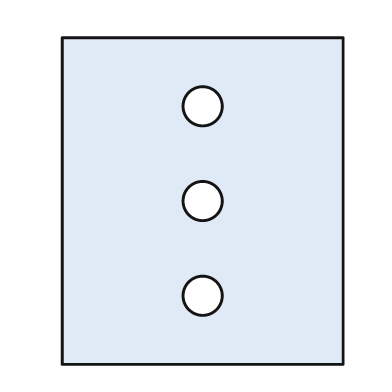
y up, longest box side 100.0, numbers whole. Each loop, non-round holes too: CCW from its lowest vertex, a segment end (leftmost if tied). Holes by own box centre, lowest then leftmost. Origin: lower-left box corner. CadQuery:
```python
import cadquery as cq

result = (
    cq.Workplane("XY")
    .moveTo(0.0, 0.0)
    .lineTo(86.0, 0.0)
    .lineTo(86.0, 100.0)
    .lineTo(0.0, 100.0)
    .close()
    .moveTo(43.0, 21.0)
    .circle(6.0)
    .moveTo(43.0, 50.0)
    .circle(6.0)
    .moveTo(43.0, 79.0)
    .circle(6.0)
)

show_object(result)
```